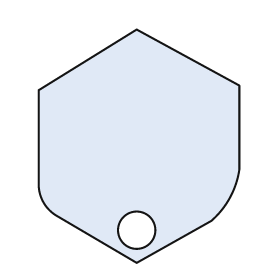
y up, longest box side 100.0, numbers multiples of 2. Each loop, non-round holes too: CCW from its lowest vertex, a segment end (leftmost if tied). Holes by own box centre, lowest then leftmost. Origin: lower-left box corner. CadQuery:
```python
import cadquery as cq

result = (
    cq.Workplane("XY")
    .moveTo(42.0, 0.0)
    .lineTo(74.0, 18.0)
    .threePointArc((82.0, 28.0), (86.0, 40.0))
    .lineTo(86.0, 76.0)
    .lineTo(42.0, 100.0)
    .lineTo(0.0, 74.0)
    .lineTo(0.0, 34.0)
    .threePointArc((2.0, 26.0), (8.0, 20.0))
    .close()
    .moveTo(42.0, 14.0)
    .circle(8.0)
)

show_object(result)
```